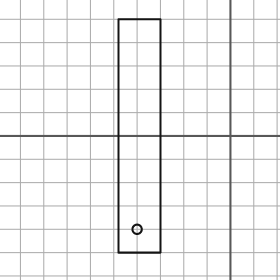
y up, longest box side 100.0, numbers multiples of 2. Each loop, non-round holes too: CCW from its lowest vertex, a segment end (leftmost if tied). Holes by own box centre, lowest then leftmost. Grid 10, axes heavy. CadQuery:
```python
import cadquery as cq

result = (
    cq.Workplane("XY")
    .moveTo(-48.0, -50.0)
    .lineTo(-30.0, -50.0)
    .lineTo(-30.0, 50.0)
    .lineTo(-48.0, 50.0)
    .close()
    .moveTo(-40.0, -40.0)
    .circle(2.0)
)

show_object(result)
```